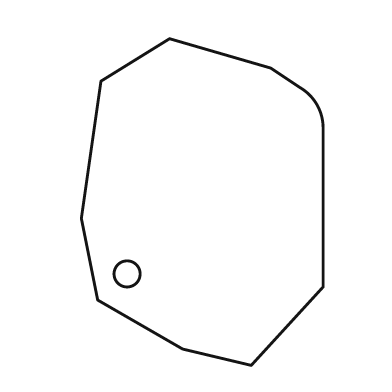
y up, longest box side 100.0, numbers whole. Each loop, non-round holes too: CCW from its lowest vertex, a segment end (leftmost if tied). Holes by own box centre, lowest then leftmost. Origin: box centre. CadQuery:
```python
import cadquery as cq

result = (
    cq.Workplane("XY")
    .moveTo(15.0, -50.0)
    .lineTo(37.0, -26.0)
    .lineTo(37.0, 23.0)
    .threePointArc((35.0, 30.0), (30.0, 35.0))
    .lineTo(21.0, 41.0)
    .lineTo(-10.0, 50.0)
    .lineTo(-31.0, 37.0)
    .lineTo(-37.0, -5.0)
    .lineTo(-32.0, -30.0)
    .lineTo(-6.0, -45.0)
    .close()
    .moveTo(-23.0, -22.0)
    .circle(4.0)
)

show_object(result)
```